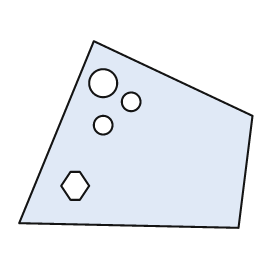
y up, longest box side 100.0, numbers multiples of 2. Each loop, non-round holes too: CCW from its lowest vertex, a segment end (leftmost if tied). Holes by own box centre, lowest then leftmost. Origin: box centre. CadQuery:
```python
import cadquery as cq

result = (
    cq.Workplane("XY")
    .moveTo(44.0, -40.0)
    .lineTo(50.0, 8.0)
    .lineTo(-18.0, 40.0)
    .lineTo(-50.0, -38.0)
    .close()
    .moveTo(-28.0, -28.0)
    .lineTo(-24.0, -28.0)
    .lineTo(-20.0, -22.0)
    .lineTo(-24.0, -16.0)
    .lineTo(-28.0, -16.0)
    .lineTo(-32.0, -22.0)
    .close()
    .moveTo(-14.0, 4.0)
    .circle(4.0)
    .moveTo(-2.0, 14.0)
    .circle(4.0)
    .moveTo(-14.0, 22.0)
    .circle(6.0)
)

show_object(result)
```